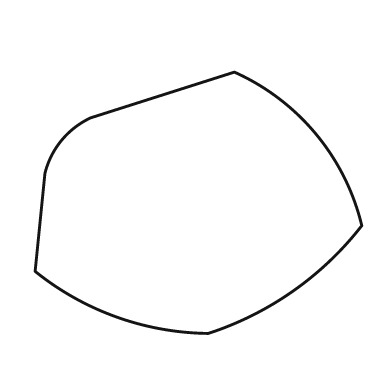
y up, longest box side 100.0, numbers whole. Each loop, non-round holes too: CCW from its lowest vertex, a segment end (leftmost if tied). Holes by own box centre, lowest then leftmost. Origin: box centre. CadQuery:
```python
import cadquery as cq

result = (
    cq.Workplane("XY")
    .moveTo(3.0, -40.0)
    .threePointArc((29.0, -27.0), (50.0, -7.0))
    .threePointArc((36.0, 21.0), (11.0, 40.0))
    .lineTo(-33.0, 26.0)
    .threePointArc((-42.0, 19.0), (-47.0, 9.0))
    .lineTo(-50.0, -21.0)
    .threePointArc((-25.0, -35.0), (3.0, -40.0))
    .close()
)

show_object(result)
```